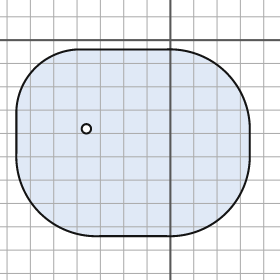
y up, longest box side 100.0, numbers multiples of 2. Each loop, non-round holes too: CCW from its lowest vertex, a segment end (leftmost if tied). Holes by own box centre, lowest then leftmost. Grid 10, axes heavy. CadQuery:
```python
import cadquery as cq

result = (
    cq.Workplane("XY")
    .moveTo(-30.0, -84.0)
    .lineTo(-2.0, -84.0)
    .threePointArc((24.0, -74.0), (34.0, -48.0))
    .lineTo(34.0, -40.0)
    .threePointArc((24.0, -14.0), (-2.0, -4.0))
    .lineTo(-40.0, -4.0)
    .threePointArc((-58.0, -12.0), (-66.0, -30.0))
    .lineTo(-66.0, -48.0)
    .threePointArc((-56.0, -74.0), (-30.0, -84.0))
    .close()
    .moveTo(-36.0, -38.0)
    .circle(2.0)
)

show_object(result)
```